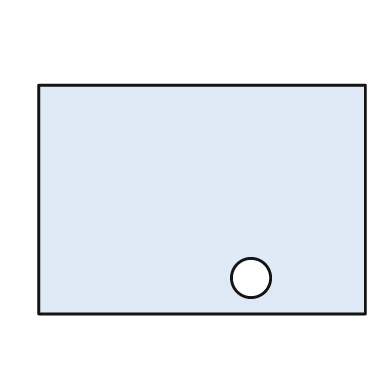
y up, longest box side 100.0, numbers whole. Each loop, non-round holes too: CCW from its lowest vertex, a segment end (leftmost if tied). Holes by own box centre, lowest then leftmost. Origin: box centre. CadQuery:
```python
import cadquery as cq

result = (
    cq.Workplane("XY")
    .moveTo(-50.0, -35.0)
    .lineTo(50.0, -35.0)
    .lineTo(50.0, 35.0)
    .lineTo(-50.0, 35.0)
    .close()
    .moveTo(15.0, -24.0)
    .circle(6.0)
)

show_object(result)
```